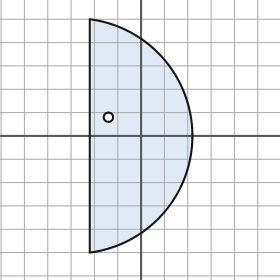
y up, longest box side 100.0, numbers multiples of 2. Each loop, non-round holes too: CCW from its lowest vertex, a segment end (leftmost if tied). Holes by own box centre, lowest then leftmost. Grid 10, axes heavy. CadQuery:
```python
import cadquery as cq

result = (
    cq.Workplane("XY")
    .moveTo(-22.0, -50.0)
    .threePointArc((22.0, 0.0), (-22.0, 50.0))
    .close()
    .moveTo(-14.0, 8.0)
    .circle(2.0)
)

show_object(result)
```